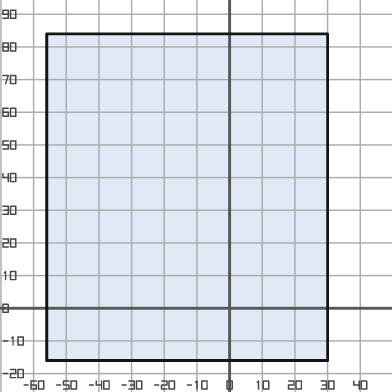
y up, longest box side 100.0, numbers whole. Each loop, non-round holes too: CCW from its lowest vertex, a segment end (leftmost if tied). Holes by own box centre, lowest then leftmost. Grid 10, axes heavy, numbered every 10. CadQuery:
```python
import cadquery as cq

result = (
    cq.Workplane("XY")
    .moveTo(-56.0, -16.0)
    .lineTo(30.0, -16.0)
    .lineTo(30.0, 84.0)
    .lineTo(-56.0, 84.0)
    .close()
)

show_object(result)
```